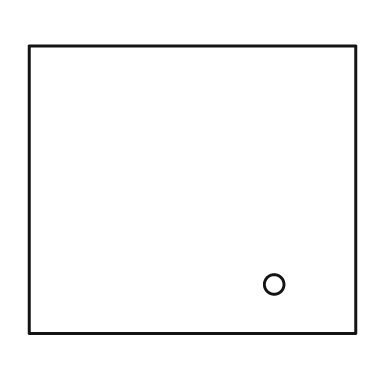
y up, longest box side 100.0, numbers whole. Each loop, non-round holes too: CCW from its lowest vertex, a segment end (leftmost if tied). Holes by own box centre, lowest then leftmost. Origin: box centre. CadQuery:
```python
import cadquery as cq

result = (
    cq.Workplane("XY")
    .moveTo(-50.0, -44.0)
    .lineTo(50.0, -44.0)
    .lineTo(50.0, 44.0)
    .lineTo(-50.0, 44.0)
    .close()
    .moveTo(25.0, -29.0)
    .circle(3.0)
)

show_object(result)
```